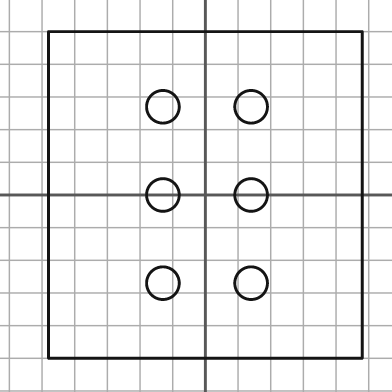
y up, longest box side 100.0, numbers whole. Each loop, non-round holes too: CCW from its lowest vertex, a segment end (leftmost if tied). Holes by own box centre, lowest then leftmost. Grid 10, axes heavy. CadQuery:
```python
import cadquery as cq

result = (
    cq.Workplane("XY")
    .moveTo(-48.0, -50.0)
    .lineTo(48.0, -50.0)
    .lineTo(48.0, 50.0)
    .lineTo(-48.0, 50.0)
    .close()
    .moveTo(-13.0, -27.0)
    .circle(5.0)
    .moveTo(14.0, -27.0)
    .circle(5.0)
    .moveTo(-13.0, 0.0)
    .circle(5.0)
    .moveTo(14.0, 0.0)
    .circle(5.0)
    .moveTo(-13.0, 27.0)
    .circle(5.0)
    .moveTo(14.0, 27.0)
    .circle(5.0)
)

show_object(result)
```